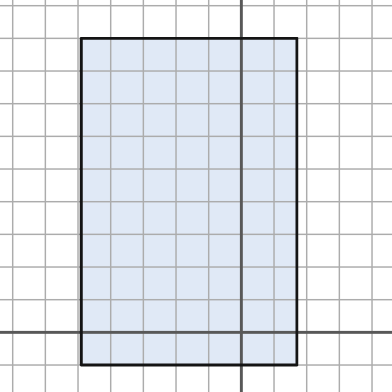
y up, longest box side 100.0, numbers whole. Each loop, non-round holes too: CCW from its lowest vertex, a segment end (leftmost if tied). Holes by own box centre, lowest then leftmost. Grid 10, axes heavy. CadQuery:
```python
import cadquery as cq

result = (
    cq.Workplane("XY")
    .moveTo(-49.0, -10.0)
    .lineTo(17.0, -10.0)
    .lineTo(17.0, 90.0)
    .lineTo(-49.0, 90.0)
    .close()
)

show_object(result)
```